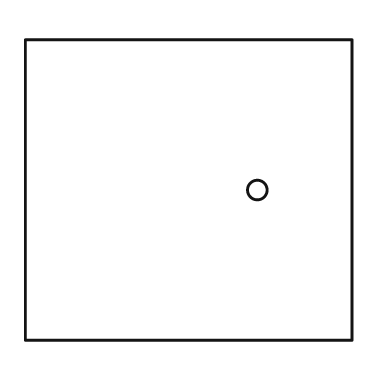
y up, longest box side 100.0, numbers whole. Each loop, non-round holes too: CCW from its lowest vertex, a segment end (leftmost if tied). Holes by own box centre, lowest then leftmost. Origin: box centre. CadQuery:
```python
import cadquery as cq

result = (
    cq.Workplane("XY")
    .moveTo(-50.0, -46.0)
    .lineTo(50.0, -46.0)
    .lineTo(50.0, 46.0)
    .lineTo(-50.0, 46.0)
    .close()
    .moveTo(21.0, 0.0)
    .circle(3.0)
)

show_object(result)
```